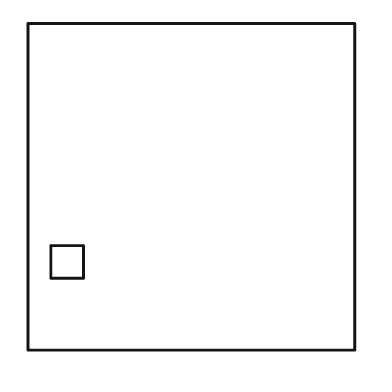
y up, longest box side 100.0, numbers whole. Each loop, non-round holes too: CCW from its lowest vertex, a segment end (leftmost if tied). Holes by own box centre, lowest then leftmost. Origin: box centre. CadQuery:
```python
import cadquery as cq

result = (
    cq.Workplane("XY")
    .moveTo(-50.0, -50.0)
    .lineTo(50.0, -50.0)
    .lineTo(50.0, 50.0)
    .lineTo(-50.0, 50.0)
    .close()
    .moveTo(-43.0, -28.0)
    .lineTo(-33.0, -28.0)
    .lineTo(-33.0, -18.0)
    .lineTo(-43.0, -18.0)
    .close()
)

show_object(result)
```